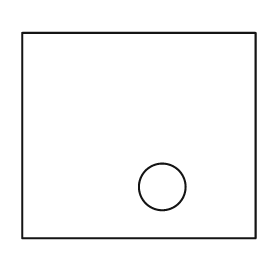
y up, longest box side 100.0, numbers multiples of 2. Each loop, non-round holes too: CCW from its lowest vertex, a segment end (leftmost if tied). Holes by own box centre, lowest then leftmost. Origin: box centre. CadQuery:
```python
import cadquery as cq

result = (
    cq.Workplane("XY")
    .moveTo(-50.0, -44.0)
    .lineTo(50.0, -44.0)
    .lineTo(50.0, 44.0)
    .lineTo(-50.0, 44.0)
    .close()
    .moveTo(10.0, -22.0)
    .circle(10.0)
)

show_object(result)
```